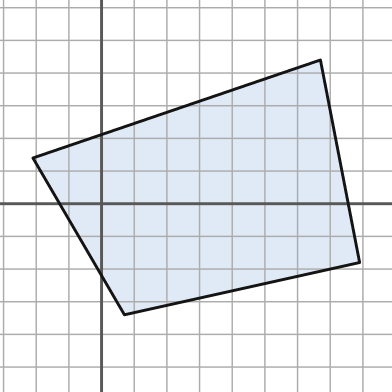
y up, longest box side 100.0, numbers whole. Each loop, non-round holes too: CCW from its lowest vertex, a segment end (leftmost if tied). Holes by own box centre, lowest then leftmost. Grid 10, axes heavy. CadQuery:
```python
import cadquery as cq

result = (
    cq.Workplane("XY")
    .moveTo(7.0, -34.0)
    .lineTo(79.0, -18.0)
    .lineTo(67.0, 44.0)
    .lineTo(-21.0, 14.0)
    .close()
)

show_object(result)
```